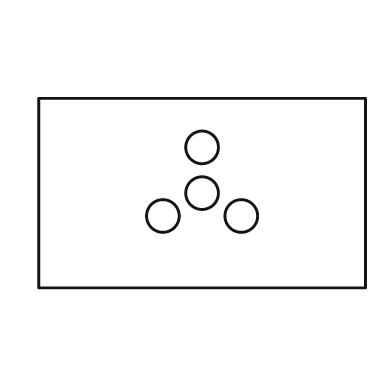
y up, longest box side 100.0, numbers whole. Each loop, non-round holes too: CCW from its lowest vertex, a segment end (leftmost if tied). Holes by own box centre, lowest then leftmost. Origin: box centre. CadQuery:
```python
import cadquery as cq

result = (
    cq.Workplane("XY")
    .moveTo(-50.0, -29.0)
    .lineTo(50.0, -29.0)
    .lineTo(50.0, 29.0)
    .lineTo(-50.0, 29.0)
    .close()
    .moveTo(-12.0, -7.0)
    .circle(5.0)
    .moveTo(12.0, -7.0)
    .circle(5.0)
    .moveTo(0.0, 0.0)
    .circle(5.0)
    .moveTo(0.0, 14.0)
    .circle(5.0)
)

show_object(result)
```